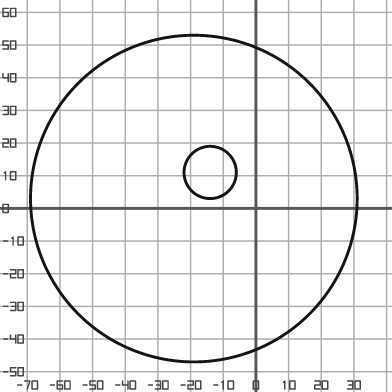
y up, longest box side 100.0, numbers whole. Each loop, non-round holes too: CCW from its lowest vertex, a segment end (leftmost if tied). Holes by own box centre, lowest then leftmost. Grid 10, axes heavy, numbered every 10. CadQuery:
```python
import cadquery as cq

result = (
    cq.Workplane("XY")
    .moveTo(-19.0, 3.0)
    .circle(50.0)
    .moveTo(-14.0, 11.0)
    .circle(8.0)
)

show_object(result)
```